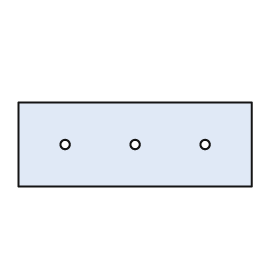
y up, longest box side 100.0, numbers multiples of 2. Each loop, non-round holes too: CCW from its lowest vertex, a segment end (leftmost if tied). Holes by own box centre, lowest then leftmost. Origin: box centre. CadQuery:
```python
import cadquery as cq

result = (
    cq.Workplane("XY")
    .moveTo(-50.0, -18.0)
    .lineTo(50.0, -18.0)
    .lineTo(50.0, 18.0)
    .lineTo(-50.0, 18.0)
    .close()
    .moveTo(-30.0, 0.0)
    .circle(2.0)
    .moveTo(0.0, 0.0)
    .circle(2.0)
    .moveTo(30.0, 0.0)
    .circle(2.0)
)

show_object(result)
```